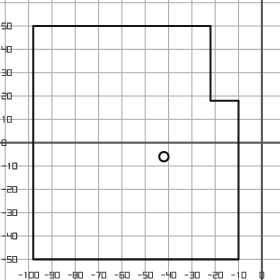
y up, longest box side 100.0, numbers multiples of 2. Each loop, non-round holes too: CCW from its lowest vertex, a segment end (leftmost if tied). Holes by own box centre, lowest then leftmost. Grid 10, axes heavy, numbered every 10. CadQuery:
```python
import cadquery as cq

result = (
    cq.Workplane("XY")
    .moveTo(-98.0, -50.0)
    .lineTo(-10.0, -50.0)
    .lineTo(-10.0, 18.0)
    .lineTo(-22.0, 18.0)
    .lineTo(-22.0, 50.0)
    .lineTo(-98.0, 50.0)
    .close()
    .moveTo(-42.0, -6.0)
    .circle(2.0)
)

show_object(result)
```